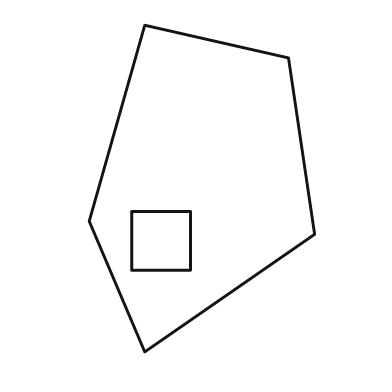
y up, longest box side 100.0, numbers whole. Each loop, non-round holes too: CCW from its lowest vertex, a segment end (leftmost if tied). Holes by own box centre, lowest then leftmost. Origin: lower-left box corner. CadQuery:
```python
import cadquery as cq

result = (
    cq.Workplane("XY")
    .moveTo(17.0, 0.0)
    .lineTo(69.0, 36.0)
    .lineTo(61.0, 90.0)
    .lineTo(17.0, 100.0)
    .lineTo(0.0, 40.0)
    .close()
    .moveTo(13.0, 25.0)
    .lineTo(31.0, 25.0)
    .lineTo(31.0, 43.0)
    .lineTo(13.0, 43.0)
    .close()
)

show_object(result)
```